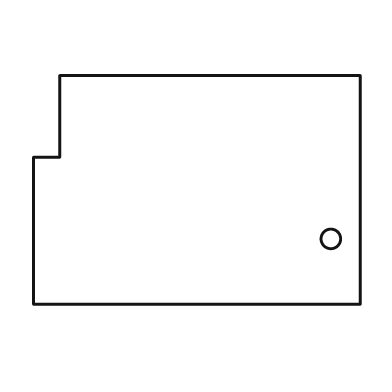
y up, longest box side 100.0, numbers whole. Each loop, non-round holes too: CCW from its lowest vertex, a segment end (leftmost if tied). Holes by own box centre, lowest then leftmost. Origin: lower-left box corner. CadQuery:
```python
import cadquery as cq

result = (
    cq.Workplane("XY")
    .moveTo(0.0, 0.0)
    .lineTo(100.0, 0.0)
    .lineTo(100.0, 70.0)
    .lineTo(8.0, 70.0)
    .lineTo(8.0, 45.0)
    .lineTo(0.0, 45.0)
    .close()
    .moveTo(91.0, 20.0)
    .circle(3.0)
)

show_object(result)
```